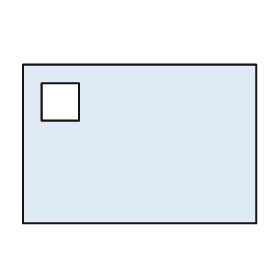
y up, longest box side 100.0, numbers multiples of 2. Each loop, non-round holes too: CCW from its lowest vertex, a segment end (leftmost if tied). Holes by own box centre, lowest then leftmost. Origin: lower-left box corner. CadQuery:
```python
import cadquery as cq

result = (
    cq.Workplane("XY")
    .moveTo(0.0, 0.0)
    .lineTo(100.0, 0.0)
    .lineTo(100.0, 68.0)
    .lineTo(0.0, 68.0)
    .close()
    .moveTo(8.0, 44.0)
    .lineTo(24.0, 44.0)
    .lineTo(24.0, 60.0)
    .lineTo(8.0, 60.0)
    .close()
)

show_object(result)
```